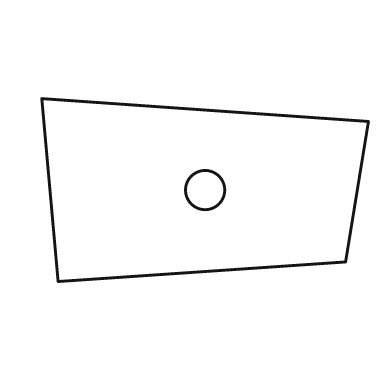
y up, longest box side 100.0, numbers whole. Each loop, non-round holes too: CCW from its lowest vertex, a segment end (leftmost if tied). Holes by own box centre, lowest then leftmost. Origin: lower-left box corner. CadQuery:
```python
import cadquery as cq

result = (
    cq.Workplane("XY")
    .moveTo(5.0, 0.0)
    .lineTo(93.0, 6.0)
    .lineTo(100.0, 49.0)
    .lineTo(0.0, 56.0)
    .close()
    .moveTo(50.0, 28.0)
    .circle(6.0)
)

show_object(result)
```